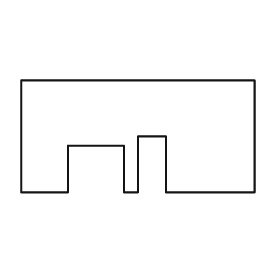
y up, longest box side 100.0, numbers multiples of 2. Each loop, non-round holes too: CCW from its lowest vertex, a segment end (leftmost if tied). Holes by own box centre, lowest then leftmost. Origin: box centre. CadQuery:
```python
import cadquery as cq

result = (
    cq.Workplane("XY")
    .moveTo(-50.0, -24.0)
    .lineTo(-30.0, -24.0)
    .lineTo(-30.0, -4.0)
    .lineTo(-6.0, -4.0)
    .lineTo(-6.0, -24.0)
    .lineTo(0.0, -24.0)
    .lineTo(0.0, 0.0)
    .lineTo(12.0, 0.0)
    .lineTo(12.0, -24.0)
    .lineTo(50.0, -24.0)
    .lineTo(50.0, 24.0)
    .lineTo(-50.0, 24.0)
    .close()
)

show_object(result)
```